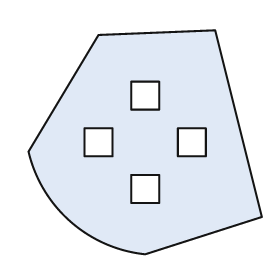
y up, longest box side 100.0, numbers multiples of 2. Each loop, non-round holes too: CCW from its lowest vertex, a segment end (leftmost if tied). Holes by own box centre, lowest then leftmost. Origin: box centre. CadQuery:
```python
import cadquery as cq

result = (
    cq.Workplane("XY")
    .moveTo(0.0, -48.0)
    .lineTo(50.0, -32.0)
    .lineTo(30.0, 48.0)
    .lineTo(-20.0, 46.0)
    .lineTo(-50.0, -4.0)
    .threePointArc((-32.0, -34.0), (0.0, -48.0))
    .close()
    .moveTo(-6.0, -26.0)
    .lineTo(6.0, -26.0)
    .lineTo(6.0, -14.0)
    .lineTo(-6.0, -14.0)
    .close()
    .moveTo(-26.0, -6.0)
    .lineTo(-14.0, -6.0)
    .lineTo(-14.0, 6.0)
    .lineTo(-26.0, 6.0)
    .close()
    .moveTo(14.0, -6.0)
    .lineTo(26.0, -6.0)
    .lineTo(26.0, 6.0)
    .lineTo(14.0, 6.0)
    .close()
    .moveTo(-6.0, 14.0)
    .lineTo(6.0, 14.0)
    .lineTo(6.0, 26.0)
    .lineTo(-6.0, 26.0)
    .close()
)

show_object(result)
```